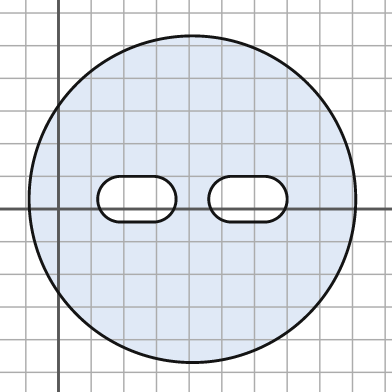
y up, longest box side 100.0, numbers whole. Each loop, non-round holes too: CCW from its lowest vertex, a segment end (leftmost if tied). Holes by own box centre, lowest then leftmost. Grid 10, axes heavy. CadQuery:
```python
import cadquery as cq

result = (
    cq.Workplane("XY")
    .moveTo(41.0, 3.0)
    .circle(50.0)
    .moveTo(19.0, -4.0)
    .lineTo(29.0, -4.0)
    .threePointArc((36.0, 3.0), (29.0, 10.0))
    .lineTo(19.0, 10.0)
    .threePointArc((12.0, 3.0), (19.0, -4.0))
    .close()
    .moveTo(53.0, -4.0)
    .lineTo(63.0, -4.0)
    .threePointArc((70.0, 3.0), (63.0, 10.0))
    .lineTo(53.0, 10.0)
    .threePointArc((46.0, 3.0), (53.0, -4.0))
    .close()
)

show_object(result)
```